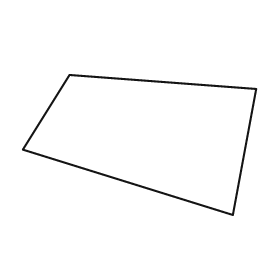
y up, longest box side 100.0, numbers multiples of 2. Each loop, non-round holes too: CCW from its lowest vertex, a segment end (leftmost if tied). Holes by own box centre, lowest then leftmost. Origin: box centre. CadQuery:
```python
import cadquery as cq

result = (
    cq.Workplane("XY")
    .moveTo(40.0, -30.0)
    .lineTo(50.0, 24.0)
    .lineTo(-30.0, 30.0)
    .lineTo(-50.0, -2.0)
    .close()
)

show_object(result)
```